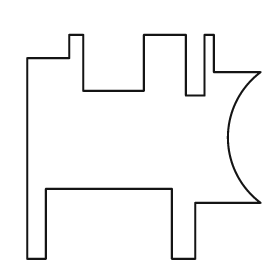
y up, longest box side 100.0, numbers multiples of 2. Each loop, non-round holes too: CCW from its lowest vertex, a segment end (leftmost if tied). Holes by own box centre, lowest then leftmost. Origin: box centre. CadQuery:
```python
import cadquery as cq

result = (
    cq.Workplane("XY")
    .moveTo(-50.0, -48.0)
    .lineTo(-42.0, -48.0)
    .lineTo(-42.0, -18.0)
    .lineTo(12.0, -18.0)
    .lineTo(12.0, -48.0)
    .lineTo(22.0, -48.0)
    .lineTo(22.0, -24.0)
    .lineTo(50.0, -24.0)
    .threePointArc((36.0, 4.0), (50.0, 32.0))
    .lineTo(30.0, 32.0)
    .lineTo(30.0, 48.0)
    .lineTo(26.0, 48.0)
    .lineTo(26.0, 22.0)
    .lineTo(18.0, 22.0)
    .lineTo(18.0, 48.0)
    .lineTo(0.0, 48.0)
    .lineTo(0.0, 24.0)
    .lineTo(-26.0, 24.0)
    .lineTo(-26.0, 48.0)
    .lineTo(-32.0, 48.0)
    .lineTo(-32.0, 38.0)
    .lineTo(-50.0, 38.0)
    .close()
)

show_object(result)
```